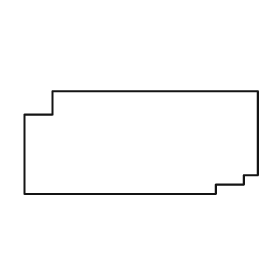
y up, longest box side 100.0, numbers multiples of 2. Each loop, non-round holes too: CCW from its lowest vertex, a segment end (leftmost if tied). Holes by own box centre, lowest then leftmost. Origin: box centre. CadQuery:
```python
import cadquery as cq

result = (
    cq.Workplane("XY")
    .moveTo(-50.0, -22.0)
    .lineTo(32.0, -22.0)
    .lineTo(32.0, -18.0)
    .lineTo(44.0, -18.0)
    .lineTo(44.0, -14.0)
    .lineTo(50.0, -14.0)
    .lineTo(50.0, 22.0)
    .lineTo(-38.0, 22.0)
    .lineTo(-38.0, 12.0)
    .lineTo(-50.0, 12.0)
    .close()
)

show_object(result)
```